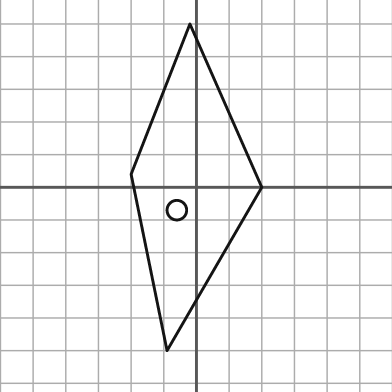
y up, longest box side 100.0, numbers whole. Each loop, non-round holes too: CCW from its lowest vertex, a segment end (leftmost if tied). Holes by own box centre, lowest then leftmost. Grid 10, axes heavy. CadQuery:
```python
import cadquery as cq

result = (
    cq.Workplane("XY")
    .moveTo(-9.0, -50.0)
    .lineTo(20.0, 0.0)
    .lineTo(-2.0, 50.0)
    .lineTo(-20.0, 4.0)
    .close()
    .moveTo(-6.0, -7.0)
    .circle(3.0)
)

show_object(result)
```